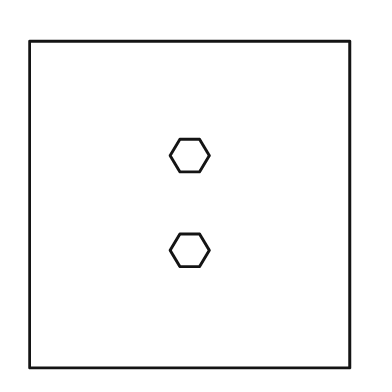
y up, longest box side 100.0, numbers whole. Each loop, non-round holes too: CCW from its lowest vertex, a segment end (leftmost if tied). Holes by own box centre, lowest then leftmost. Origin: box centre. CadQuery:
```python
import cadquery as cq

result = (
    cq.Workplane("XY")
    .moveTo(-49.0, -50.0)
    .lineTo(49.0, -50.0)
    .lineTo(49.0, 50.0)
    .lineTo(-49.0, 50.0)
    .close()
    .moveTo(-3.0, -19.0)
    .lineTo(3.0, -19.0)
    .lineTo(6.0, -14.0)
    .lineTo(3.0, -9.0)
    .lineTo(-3.0, -9.0)
    .lineTo(-6.0, -14.0)
    .close()
    .moveTo(-3.0, 10.0)
    .lineTo(3.0, 10.0)
    .lineTo(6.0, 15.0)
    .lineTo(3.0, 20.0)
    .lineTo(-3.0, 20.0)
    .lineTo(-6.0, 15.0)
    .close()
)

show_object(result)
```